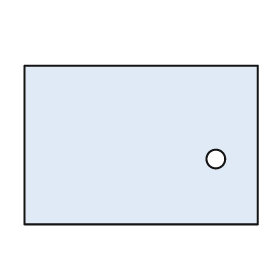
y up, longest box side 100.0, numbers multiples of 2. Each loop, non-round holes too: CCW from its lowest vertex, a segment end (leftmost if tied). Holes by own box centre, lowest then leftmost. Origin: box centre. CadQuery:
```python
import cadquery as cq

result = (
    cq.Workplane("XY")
    .moveTo(-50.0, -34.0)
    .lineTo(50.0, -34.0)
    .lineTo(50.0, 34.0)
    .lineTo(-50.0, 34.0)
    .close()
    .moveTo(32.0, -6.0)
    .circle(4.0)
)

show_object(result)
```